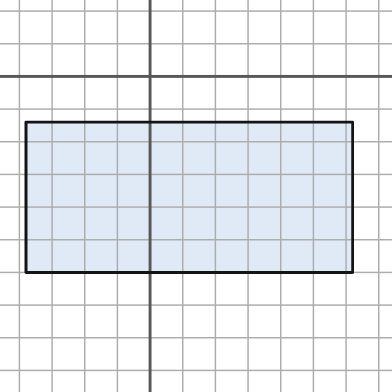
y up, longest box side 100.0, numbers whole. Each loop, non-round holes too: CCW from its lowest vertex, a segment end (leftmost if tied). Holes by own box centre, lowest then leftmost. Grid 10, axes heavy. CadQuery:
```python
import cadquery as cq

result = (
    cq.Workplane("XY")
    .moveTo(-38.0, -60.0)
    .lineTo(62.0, -60.0)
    .lineTo(62.0, -14.0)
    .lineTo(-38.0, -14.0)
    .close()
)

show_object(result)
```